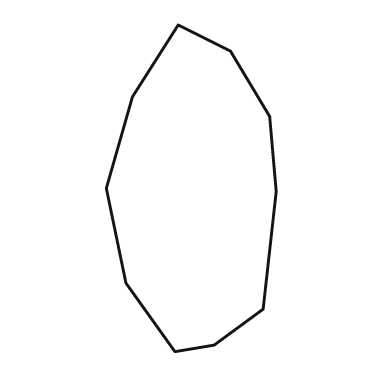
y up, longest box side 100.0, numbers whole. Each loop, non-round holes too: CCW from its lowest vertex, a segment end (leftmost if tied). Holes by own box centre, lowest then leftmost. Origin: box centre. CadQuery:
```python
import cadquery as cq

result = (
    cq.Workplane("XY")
    .moveTo(-5.0, -50.0)
    .lineTo(7.0, -48.0)
    .lineTo(22.0, -37.0)
    .lineTo(26.0, -1.0)
    .lineTo(24.0, 22.0)
    .lineTo(12.0, 42.0)
    .lineTo(-4.0, 50.0)
    .lineTo(-18.0, 28.0)
    .lineTo(-26.0, 0.0)
    .lineTo(-20.0, -29.0)
    .close()
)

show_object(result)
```